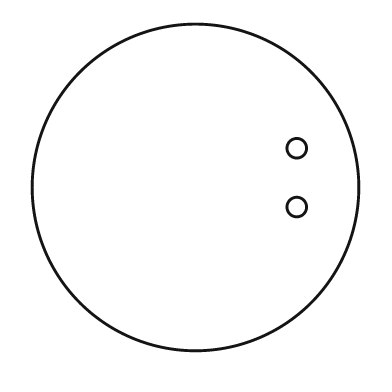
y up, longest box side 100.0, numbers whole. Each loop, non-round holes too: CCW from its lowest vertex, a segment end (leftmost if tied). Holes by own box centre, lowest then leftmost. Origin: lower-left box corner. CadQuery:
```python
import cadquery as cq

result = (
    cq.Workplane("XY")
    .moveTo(50.0, 50.0)
    .circle(50.0)
    .moveTo(81.0, 44.0)
    .circle(3.0)
    .moveTo(81.0, 62.0)
    .circle(3.0)
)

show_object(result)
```